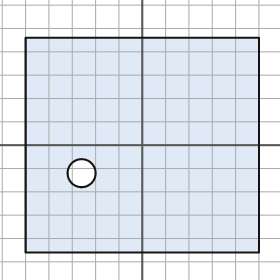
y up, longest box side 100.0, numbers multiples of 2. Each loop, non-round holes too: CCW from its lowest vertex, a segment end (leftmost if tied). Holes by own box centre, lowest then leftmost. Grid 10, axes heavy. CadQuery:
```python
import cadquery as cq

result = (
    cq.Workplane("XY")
    .moveTo(-50.0, -46.0)
    .lineTo(50.0, -46.0)
    .lineTo(50.0, 46.0)
    .lineTo(-50.0, 46.0)
    .close()
    .moveTo(-26.0, -12.0)
    .circle(6.0)
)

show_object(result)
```